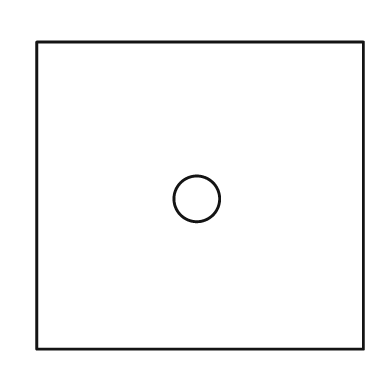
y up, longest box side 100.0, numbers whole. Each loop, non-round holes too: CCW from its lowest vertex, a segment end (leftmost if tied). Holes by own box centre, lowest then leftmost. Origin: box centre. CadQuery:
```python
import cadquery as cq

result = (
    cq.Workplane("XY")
    .moveTo(-50.0, -47.0)
    .lineTo(50.0, -47.0)
    .lineTo(50.0, 47.0)
    .lineTo(-50.0, 47.0)
    .close()
    .moveTo(-1.0, -1.0)
    .circle(7.0)
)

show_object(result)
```